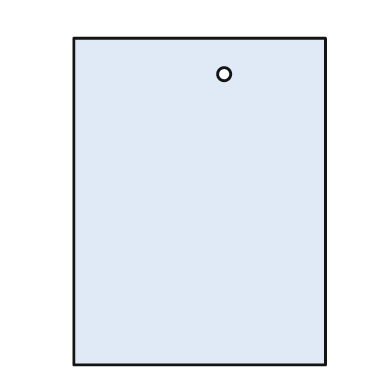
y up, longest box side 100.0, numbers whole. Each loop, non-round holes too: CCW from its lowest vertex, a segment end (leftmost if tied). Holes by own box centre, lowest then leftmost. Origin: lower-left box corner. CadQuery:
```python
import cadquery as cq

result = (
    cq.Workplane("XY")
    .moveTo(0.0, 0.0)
    .lineTo(77.0, 0.0)
    .lineTo(77.0, 100.0)
    .lineTo(0.0, 100.0)
    .close()
    .moveTo(46.0, 89.0)
    .circle(2.0)
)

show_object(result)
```